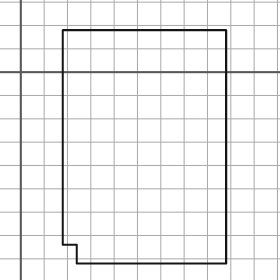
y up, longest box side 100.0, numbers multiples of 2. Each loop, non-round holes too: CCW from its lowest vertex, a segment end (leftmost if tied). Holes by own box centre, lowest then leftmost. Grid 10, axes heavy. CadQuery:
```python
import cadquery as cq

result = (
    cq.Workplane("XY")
    .moveTo(24.0, -82.0)
    .lineTo(88.0, -82.0)
    .lineTo(88.0, 18.0)
    .lineTo(18.0, 18.0)
    .lineTo(18.0, -74.0)
    .lineTo(24.0, -74.0)
    .close()
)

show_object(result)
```